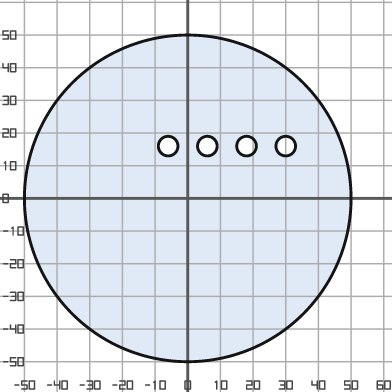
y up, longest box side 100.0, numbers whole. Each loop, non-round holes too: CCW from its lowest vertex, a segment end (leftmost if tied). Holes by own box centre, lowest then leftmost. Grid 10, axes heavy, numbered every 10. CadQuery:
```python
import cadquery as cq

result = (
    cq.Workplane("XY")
    .moveTo(0.0, 0.0)
    .circle(50.0)
    .moveTo(-6.0, 16.0)
    .circle(3.0)
    .moveTo(6.0, 16.0)
    .circle(3.0)
    .moveTo(18.0, 16.0)
    .circle(3.0)
    .moveTo(30.0, 16.0)
    .circle(3.0)
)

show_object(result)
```